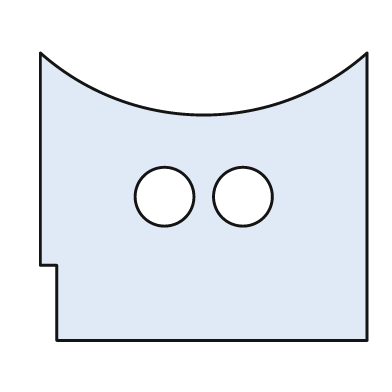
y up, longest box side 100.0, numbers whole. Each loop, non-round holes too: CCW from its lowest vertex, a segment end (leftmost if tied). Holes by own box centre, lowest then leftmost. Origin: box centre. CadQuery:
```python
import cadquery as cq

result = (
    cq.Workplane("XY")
    .moveTo(-45.0, -44.0)
    .lineTo(50.0, -44.0)
    .lineTo(50.0, 44.0)
    .threePointArc((0.0, 25.0), (-50.0, 44.0))
    .lineTo(-50.0, -21.0)
    .lineTo(-45.0, -21.0)
    .close()
    .moveTo(-12.0, 0.0)
    .circle(9.0)
    .moveTo(12.0, 0.0)
    .circle(9.0)
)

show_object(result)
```